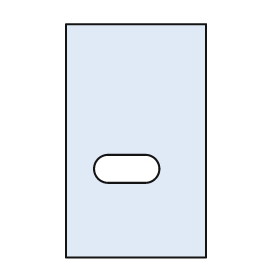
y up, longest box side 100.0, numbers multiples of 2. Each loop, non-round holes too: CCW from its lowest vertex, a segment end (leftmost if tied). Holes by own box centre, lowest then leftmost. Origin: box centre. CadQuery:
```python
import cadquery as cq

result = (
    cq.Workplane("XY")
    .moveTo(-30.0, -50.0)
    .lineTo(30.0, -50.0)
    .lineTo(30.0, 50.0)
    .lineTo(-30.0, 50.0)
    .close()
    .moveTo(-12.0, -18.0)
    .lineTo(4.0, -18.0)
    .threePointArc((10.0, -12.0), (4.0, -6.0))
    .lineTo(-12.0, -6.0)
    .threePointArc((-18.0, -12.0), (-12.0, -18.0))
    .close()
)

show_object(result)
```